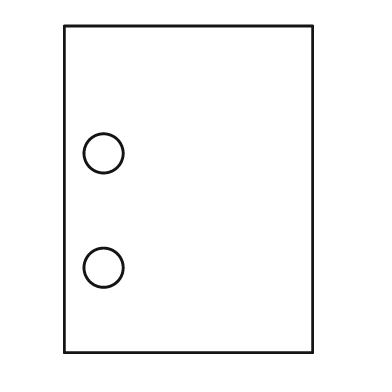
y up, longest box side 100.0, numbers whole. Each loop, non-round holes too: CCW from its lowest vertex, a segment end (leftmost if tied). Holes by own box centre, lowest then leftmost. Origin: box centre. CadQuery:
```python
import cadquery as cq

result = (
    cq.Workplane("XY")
    .moveTo(-38.0, -50.0)
    .lineTo(38.0, -50.0)
    .lineTo(38.0, 50.0)
    .lineTo(-38.0, 50.0)
    .close()
    .moveTo(-26.0, -24.0)
    .circle(6.0)
    .moveTo(-26.0, 11.0)
    .circle(6.0)
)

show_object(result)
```